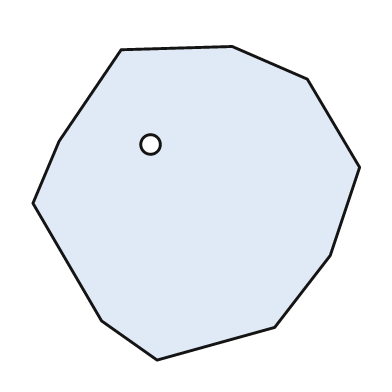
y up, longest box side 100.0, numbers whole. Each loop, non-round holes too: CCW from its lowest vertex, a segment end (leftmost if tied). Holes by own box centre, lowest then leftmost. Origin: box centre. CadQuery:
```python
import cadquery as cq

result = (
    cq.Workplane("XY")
    .moveTo(-12.0, -48.0)
    .lineTo(24.0, -38.0)
    .lineTo(41.0, -16.0)
    .lineTo(50.0, 11.0)
    .lineTo(34.0, 38.0)
    .lineTo(11.0, 48.0)
    .lineTo(-23.0, 47.0)
    .lineTo(-42.0, 19.0)
    .lineTo(-50.0, 0.0)
    .lineTo(-29.0, -36.0)
    .close()
    .moveTo(-14.0, 18.0)
    .circle(3.0)
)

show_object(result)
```